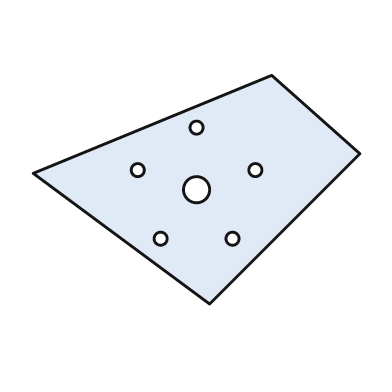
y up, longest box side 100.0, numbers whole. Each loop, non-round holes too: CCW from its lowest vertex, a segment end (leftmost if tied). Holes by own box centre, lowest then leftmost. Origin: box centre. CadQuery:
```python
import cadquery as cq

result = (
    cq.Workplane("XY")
    .moveTo(4.0, -35.0)
    .lineTo(50.0, 11.0)
    .lineTo(23.0, 35.0)
    .lineTo(-50.0, 5.0)
    .close()
    .moveTo(-11.0, -15.0)
    .circle(2.0)
    .moveTo(11.0, -15.0)
    .circle(2.0)
    .moveTo(0.0, 0.0)
    .circle(4.0)
    .moveTo(-18.0, 6.0)
    .circle(2.0)
    .moveTo(18.0, 6.0)
    .circle(2.0)
    .moveTo(0.0, 19.0)
    .circle(2.0)
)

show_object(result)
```